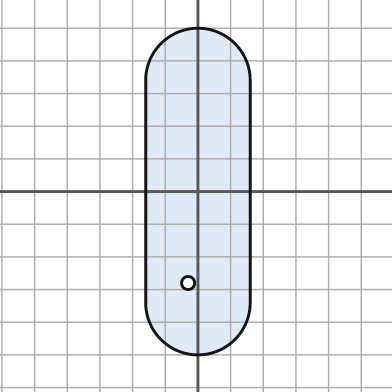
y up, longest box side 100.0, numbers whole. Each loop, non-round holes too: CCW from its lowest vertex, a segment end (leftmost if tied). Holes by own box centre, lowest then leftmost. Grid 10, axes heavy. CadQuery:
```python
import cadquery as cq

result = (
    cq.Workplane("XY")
    .moveTo(-16.0, -34.0)
    .threePointArc((0.0, -50.0), (16.0, -34.0))
    .lineTo(16.0, 34.0)
    .threePointArc((0.0, 50.0), (-16.0, 34.0))
    .close()
    .moveTo(-3.0, -28.0)
    .circle(2.0)
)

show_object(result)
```